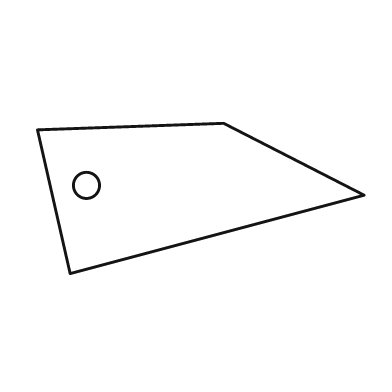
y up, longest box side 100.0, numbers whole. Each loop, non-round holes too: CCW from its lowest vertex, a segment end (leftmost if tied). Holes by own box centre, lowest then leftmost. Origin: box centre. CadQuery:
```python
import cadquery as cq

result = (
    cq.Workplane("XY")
    .moveTo(-40.0, -23.0)
    .lineTo(50.0, 1.0)
    .lineTo(7.0, 23.0)
    .lineTo(-50.0, 21.0)
    .close()
    .moveTo(-35.0, 4.0)
    .circle(4.0)
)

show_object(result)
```